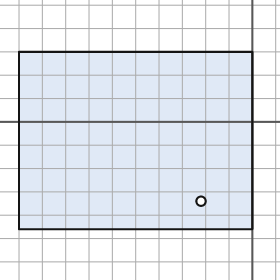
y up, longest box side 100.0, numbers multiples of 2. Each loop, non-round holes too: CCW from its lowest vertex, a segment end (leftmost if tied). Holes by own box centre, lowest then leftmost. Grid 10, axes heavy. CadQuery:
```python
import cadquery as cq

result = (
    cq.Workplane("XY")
    .moveTo(-100.0, -46.0)
    .lineTo(0.0, -46.0)
    .lineTo(0.0, 30.0)
    .lineTo(-100.0, 30.0)
    .close()
    .moveTo(-22.0, -34.0)
    .circle(2.0)
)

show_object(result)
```